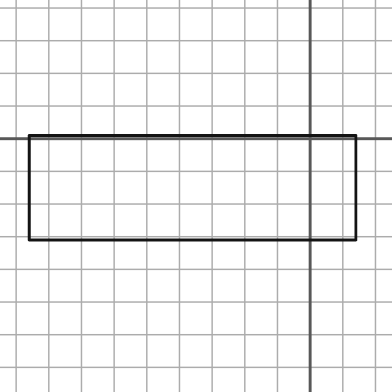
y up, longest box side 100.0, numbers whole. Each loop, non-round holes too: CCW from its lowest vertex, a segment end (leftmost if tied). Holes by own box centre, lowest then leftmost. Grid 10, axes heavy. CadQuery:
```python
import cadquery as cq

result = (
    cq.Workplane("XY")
    .moveTo(-86.0, -31.0)
    .lineTo(14.0, -31.0)
    .lineTo(14.0, 1.0)
    .lineTo(-86.0, 1.0)
    .close()
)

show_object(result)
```